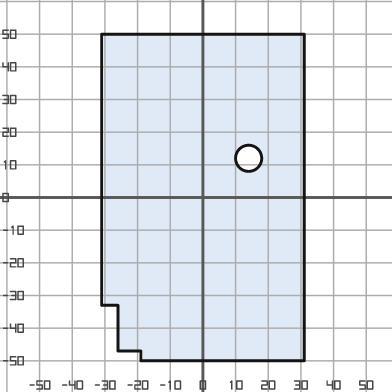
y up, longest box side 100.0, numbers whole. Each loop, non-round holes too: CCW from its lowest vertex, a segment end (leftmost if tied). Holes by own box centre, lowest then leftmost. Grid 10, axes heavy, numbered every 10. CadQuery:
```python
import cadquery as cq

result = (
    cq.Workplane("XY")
    .moveTo(-19.0, -50.0)
    .lineTo(31.0, -50.0)
    .lineTo(31.0, 50.0)
    .lineTo(-31.0, 50.0)
    .lineTo(-31.0, -33.0)
    .lineTo(-26.0, -33.0)
    .lineTo(-26.0, -47.0)
    .lineTo(-19.0, -47.0)
    .close()
    .moveTo(14.0, 12.0)
    .circle(4.0)
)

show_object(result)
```